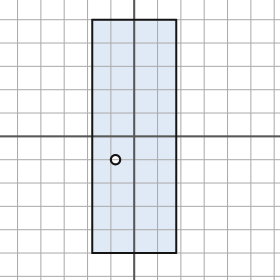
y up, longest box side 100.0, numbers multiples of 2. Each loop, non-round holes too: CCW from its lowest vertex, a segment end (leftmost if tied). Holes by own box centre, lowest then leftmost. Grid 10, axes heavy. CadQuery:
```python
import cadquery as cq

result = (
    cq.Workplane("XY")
    .moveTo(-18.0, -50.0)
    .lineTo(18.0, -50.0)
    .lineTo(18.0, 50.0)
    .lineTo(-18.0, 50.0)
    .close()
    .moveTo(-8.0, -10.0)
    .circle(2.0)
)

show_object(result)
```